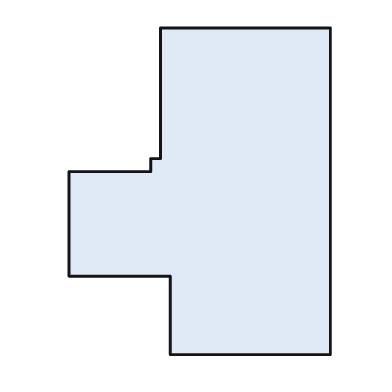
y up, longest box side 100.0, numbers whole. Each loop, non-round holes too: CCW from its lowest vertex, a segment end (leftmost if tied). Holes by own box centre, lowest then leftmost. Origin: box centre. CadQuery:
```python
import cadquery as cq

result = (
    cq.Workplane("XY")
    .moveTo(-9.0, -50.0)
    .lineTo(40.0, -50.0)
    .lineTo(40.0, 50.0)
    .lineTo(-12.0, 50.0)
    .lineTo(-12.0, 10.0)
    .lineTo(-15.0, 10.0)
    .lineTo(-15.0, 6.0)
    .lineTo(-40.0, 6.0)
    .lineTo(-40.0, -26.0)
    .lineTo(-9.0, -26.0)
    .close()
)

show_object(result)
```